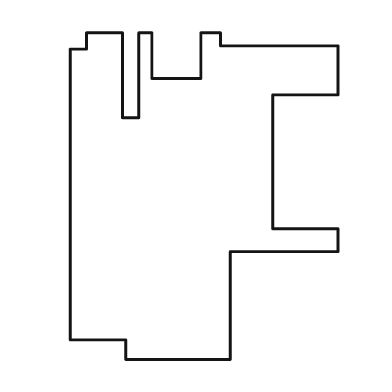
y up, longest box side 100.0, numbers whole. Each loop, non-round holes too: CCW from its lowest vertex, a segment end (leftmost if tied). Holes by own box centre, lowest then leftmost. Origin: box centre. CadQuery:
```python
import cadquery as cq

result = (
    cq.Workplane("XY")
    .moveTo(-24.0, -50.0)
    .lineTo(8.0, -50.0)
    .lineTo(8.0, -17.0)
    .lineTo(41.0, -17.0)
    .lineTo(41.0, -10.0)
    .lineTo(21.0, -10.0)
    .lineTo(21.0, 31.0)
    .lineTo(41.0, 31.0)
    .lineTo(41.0, 46.0)
    .lineTo(5.0, 46.0)
    .lineTo(5.0, 50.0)
    .lineTo(-1.0, 50.0)
    .lineTo(-1.0, 36.0)
    .lineTo(-16.0, 36.0)
    .lineTo(-16.0, 50.0)
    .lineTo(-20.0, 50.0)
    .lineTo(-20.0, 24.0)
    .lineTo(-25.0, 24.0)
    .lineTo(-25.0, 50.0)
    .lineTo(-36.0, 50.0)
    .lineTo(-36.0, 45.0)
    .lineTo(-41.0, 45.0)
    .lineTo(-41.0, -44.0)
    .lineTo(-24.0, -44.0)
    .close()
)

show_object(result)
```